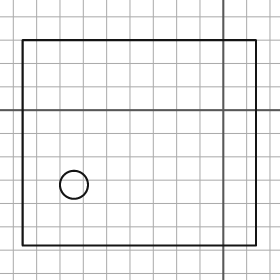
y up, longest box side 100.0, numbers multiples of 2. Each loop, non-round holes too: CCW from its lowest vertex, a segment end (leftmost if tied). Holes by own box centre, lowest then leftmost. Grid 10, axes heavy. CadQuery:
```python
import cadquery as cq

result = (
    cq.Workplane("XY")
    .moveTo(-86.0, -58.0)
    .lineTo(14.0, -58.0)
    .lineTo(14.0, 30.0)
    .lineTo(-86.0, 30.0)
    .close()
    .moveTo(-64.0, -32.0)
    .circle(6.0)
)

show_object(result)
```